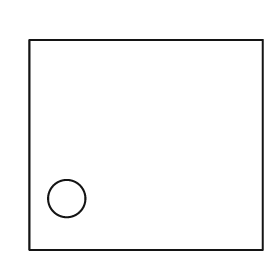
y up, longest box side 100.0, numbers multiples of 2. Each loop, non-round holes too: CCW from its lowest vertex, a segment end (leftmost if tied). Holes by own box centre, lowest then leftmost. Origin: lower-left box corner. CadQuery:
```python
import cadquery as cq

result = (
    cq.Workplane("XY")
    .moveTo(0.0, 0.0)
    .lineTo(100.0, 0.0)
    .lineTo(100.0, 90.0)
    .lineTo(0.0, 90.0)
    .close()
    .moveTo(16.0, 22.0)
    .circle(8.0)
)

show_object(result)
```